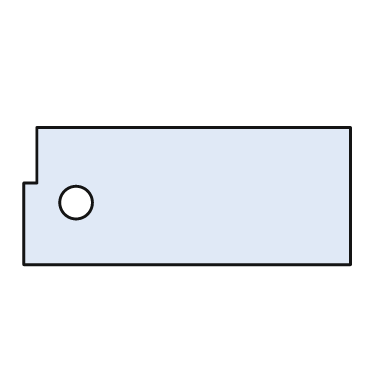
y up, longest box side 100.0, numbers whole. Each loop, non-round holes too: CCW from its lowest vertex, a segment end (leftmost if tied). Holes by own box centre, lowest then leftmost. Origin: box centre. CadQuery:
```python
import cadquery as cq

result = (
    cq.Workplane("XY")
    .moveTo(-50.0, -21.0)
    .lineTo(50.0, -21.0)
    .lineTo(50.0, 21.0)
    .lineTo(-46.0, 21.0)
    .lineTo(-46.0, 4.0)
    .lineTo(-50.0, 4.0)
    .close()
    .moveTo(-34.0, -2.0)
    .circle(5.0)
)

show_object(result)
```